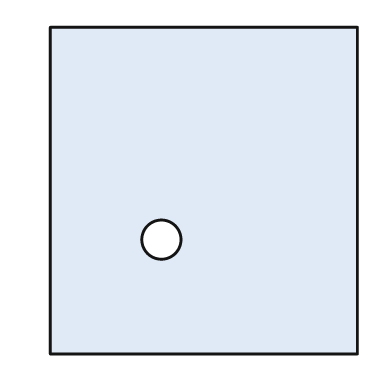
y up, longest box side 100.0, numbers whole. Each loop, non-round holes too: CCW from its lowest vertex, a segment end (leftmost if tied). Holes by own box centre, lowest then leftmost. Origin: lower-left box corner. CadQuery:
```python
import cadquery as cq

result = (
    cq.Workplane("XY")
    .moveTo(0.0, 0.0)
    .lineTo(94.0, 0.0)
    .lineTo(94.0, 100.0)
    .lineTo(0.0, 100.0)
    .close()
    .moveTo(34.0, 35.0)
    .circle(6.0)
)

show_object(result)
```